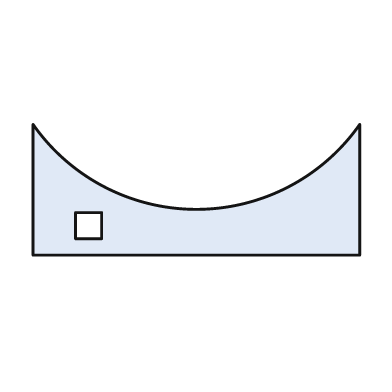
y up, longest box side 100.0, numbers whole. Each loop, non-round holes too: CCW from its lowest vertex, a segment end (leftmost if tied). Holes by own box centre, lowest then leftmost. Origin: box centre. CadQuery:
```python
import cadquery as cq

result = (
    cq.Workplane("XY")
    .moveTo(-50.0, -20.0)
    .lineTo(50.0, -20.0)
    .lineTo(50.0, 20.0)
    .threePointArc((0.0, -6.0), (-50.0, 20.0))
    .close()
    .moveTo(-37.0, -15.0)
    .lineTo(-29.0, -15.0)
    .lineTo(-29.0, -7.0)
    .lineTo(-37.0, -7.0)
    .close()
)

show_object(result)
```